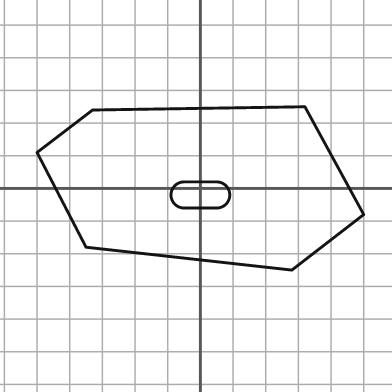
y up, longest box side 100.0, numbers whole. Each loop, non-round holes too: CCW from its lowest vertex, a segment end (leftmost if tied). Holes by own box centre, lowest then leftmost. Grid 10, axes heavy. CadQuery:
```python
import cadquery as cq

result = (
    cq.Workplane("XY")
    .moveTo(28.0, -25.0)
    .lineTo(50.0, -8.0)
    .lineTo(32.0, 25.0)
    .lineTo(-33.0, 24.0)
    .lineTo(-50.0, 11.0)
    .lineTo(-35.0, -18.0)
    .close()
    .moveTo(-5.0, -6.0)
    .lineTo(5.0, -6.0)
    .threePointArc((9.0, -2.0), (5.0, 2.0))
    .lineTo(-5.0, 2.0)
    .threePointArc((-9.0, -2.0), (-5.0, -6.0))
    .close()
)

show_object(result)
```